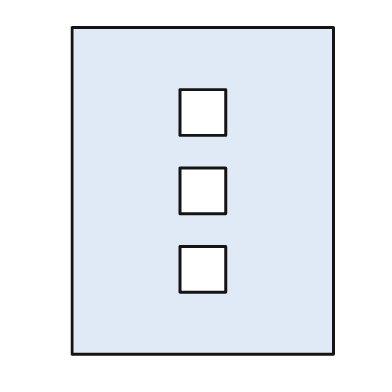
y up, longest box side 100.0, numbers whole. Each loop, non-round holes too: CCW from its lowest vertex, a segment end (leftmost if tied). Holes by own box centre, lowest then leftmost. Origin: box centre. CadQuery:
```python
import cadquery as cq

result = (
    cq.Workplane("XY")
    .moveTo(-40.0, -50.0)
    .lineTo(40.0, -50.0)
    .lineTo(40.0, 50.0)
    .lineTo(-40.0, 50.0)
    .close()
    .moveTo(-7.0, -31.0)
    .lineTo(7.0, -31.0)
    .lineTo(7.0, -17.0)
    .lineTo(-7.0, -17.0)
    .close()
    .moveTo(-7.0, -7.0)
    .lineTo(7.0, -7.0)
    .lineTo(7.0, 7.0)
    .lineTo(-7.0, 7.0)
    .close()
    .moveTo(-7.0, 17.0)
    .lineTo(7.0, 17.0)
    .lineTo(7.0, 31.0)
    .lineTo(-7.0, 31.0)
    .close()
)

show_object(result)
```